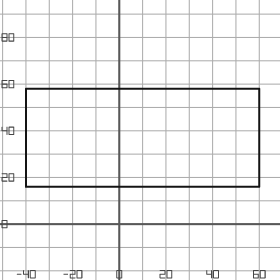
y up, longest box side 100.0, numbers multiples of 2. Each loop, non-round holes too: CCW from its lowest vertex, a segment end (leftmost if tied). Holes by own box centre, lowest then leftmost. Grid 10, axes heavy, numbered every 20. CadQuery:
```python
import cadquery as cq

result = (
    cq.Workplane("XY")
    .moveTo(-40.0, 16.0)
    .lineTo(60.0, 16.0)
    .lineTo(60.0, 58.0)
    .lineTo(-40.0, 58.0)
    .close()
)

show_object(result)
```